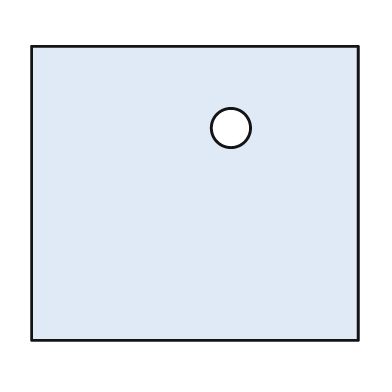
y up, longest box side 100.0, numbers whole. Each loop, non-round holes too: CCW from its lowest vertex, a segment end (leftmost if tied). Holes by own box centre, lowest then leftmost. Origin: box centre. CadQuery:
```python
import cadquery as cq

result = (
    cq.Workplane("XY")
    .moveTo(-50.0, -45.0)
    .lineTo(50.0, -45.0)
    .lineTo(50.0, 45.0)
    .lineTo(-50.0, 45.0)
    .close()
    .moveTo(11.0, 20.0)
    .circle(6.0)
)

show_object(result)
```